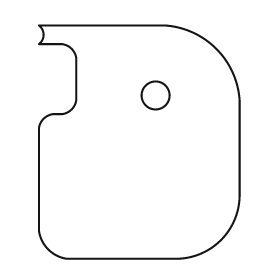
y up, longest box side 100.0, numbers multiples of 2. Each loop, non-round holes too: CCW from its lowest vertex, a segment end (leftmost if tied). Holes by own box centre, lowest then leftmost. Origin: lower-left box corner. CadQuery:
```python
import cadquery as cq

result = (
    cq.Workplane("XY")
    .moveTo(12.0, 0.0)
    .lineTo(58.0, 0.0)
    .threePointArc((78.0, 8.0), (86.0, 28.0))
    .lineTo(86.0, 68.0)
    .threePointArc((76.0, 90.0), (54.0, 100.0))
    .lineTo(0.0, 100.0)
    .threePointArc((2.0, 96.0), (0.0, 92.0))
    .lineTo(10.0, 92.0)
    .threePointArc((14.0, 90.0), (16.0, 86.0))
    .lineTo(16.0, 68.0)
    .threePointArc((14.0, 64.0), (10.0, 62.0))
    .lineTo(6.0, 62.0)
    .threePointArc((2.0, 60.0), (0.0, 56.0))
    .lineTo(0.0, 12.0)
    .threePointArc((4.0, 4.0), (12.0, 0.0))
    .close()
    .moveTo(50.0, 70.0)
    .circle(6.0)
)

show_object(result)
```